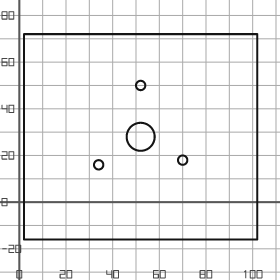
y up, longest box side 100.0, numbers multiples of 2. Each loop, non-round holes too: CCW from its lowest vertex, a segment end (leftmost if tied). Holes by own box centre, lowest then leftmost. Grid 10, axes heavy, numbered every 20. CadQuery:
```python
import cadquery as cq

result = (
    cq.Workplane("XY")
    .moveTo(2.0, -16.0)
    .lineTo(102.0, -16.0)
    .lineTo(102.0, 72.0)
    .lineTo(2.0, 72.0)
    .close()
    .moveTo(34.0, 16.0)
    .circle(2.0)
    .moveTo(70.0, 18.0)
    .circle(2.0)
    .moveTo(52.0, 28.0)
    .circle(6.0)
    .moveTo(52.0, 50.0)
    .circle(2.0)
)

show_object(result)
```